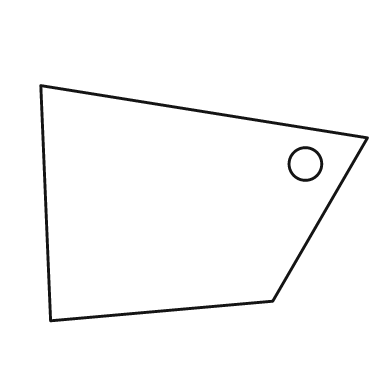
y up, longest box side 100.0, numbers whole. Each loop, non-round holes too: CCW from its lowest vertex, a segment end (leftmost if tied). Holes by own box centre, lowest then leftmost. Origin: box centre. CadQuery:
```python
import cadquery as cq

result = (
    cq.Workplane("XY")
    .moveTo(-47.0, -36.0)
    .lineTo(21.0, -30.0)
    .lineTo(50.0, 20.0)
    .lineTo(-50.0, 36.0)
    .close()
    .moveTo(31.0, 12.0)
    .circle(5.0)
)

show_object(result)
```